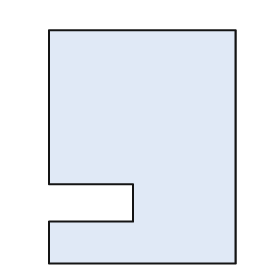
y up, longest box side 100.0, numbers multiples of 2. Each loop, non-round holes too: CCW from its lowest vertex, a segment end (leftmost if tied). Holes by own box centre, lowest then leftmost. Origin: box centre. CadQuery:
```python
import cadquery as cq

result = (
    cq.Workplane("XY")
    .moveTo(-40.0, -50.0)
    .lineTo(40.0, -50.0)
    .lineTo(40.0, 50.0)
    .lineTo(-40.0, 50.0)
    .lineTo(-40.0, -16.0)
    .lineTo(-4.0, -16.0)
    .lineTo(-4.0, -32.0)
    .lineTo(-40.0, -32.0)
    .close()
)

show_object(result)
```